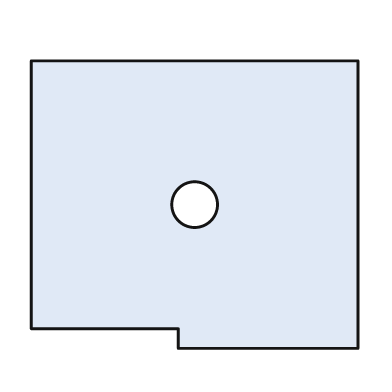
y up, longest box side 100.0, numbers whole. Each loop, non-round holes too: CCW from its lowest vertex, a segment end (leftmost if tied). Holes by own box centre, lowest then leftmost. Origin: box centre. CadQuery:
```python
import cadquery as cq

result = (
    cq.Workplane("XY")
    .moveTo(-5.0, -44.0)
    .lineTo(50.0, -44.0)
    .lineTo(50.0, 44.0)
    .lineTo(-50.0, 44.0)
    .lineTo(-50.0, -38.0)
    .lineTo(-5.0, -38.0)
    .close()
    .moveTo(0.0, 0.0)
    .circle(7.0)
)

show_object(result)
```